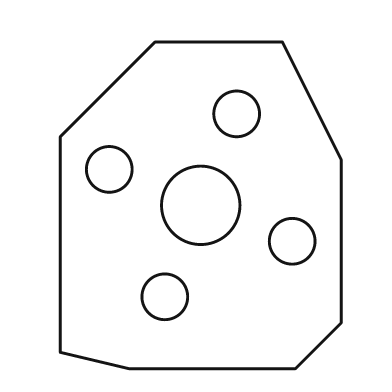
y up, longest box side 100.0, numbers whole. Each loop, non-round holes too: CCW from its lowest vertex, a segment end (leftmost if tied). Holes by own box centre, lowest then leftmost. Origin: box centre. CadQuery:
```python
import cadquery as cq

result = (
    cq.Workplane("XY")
    .moveTo(-22.0, -50.0)
    .lineTo(29.0, -50.0)
    .lineTo(43.0, -36.0)
    .lineTo(43.0, 14.0)
    .lineTo(25.0, 50.0)
    .lineTo(-14.0, 50.0)
    .lineTo(-43.0, 21.0)
    .lineTo(-43.0, -45.0)
    .close()
    .moveTo(-11.0, -28.0)
    .circle(7.0)
    .moveTo(28.0, -11.0)
    .circle(7.0)
    .moveTo(0.0, 0.0)
    .circle(12.0)
    .moveTo(-28.0, 11.0)
    .circle(7.0)
    .moveTo(11.0, 28.0)
    .circle(7.0)
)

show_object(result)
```